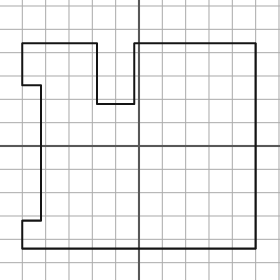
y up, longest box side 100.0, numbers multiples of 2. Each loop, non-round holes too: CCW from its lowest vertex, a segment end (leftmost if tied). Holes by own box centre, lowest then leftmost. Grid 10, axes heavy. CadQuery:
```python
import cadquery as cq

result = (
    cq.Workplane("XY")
    .moveTo(-50.0, -44.0)
    .lineTo(50.0, -44.0)
    .lineTo(50.0, 44.0)
    .lineTo(-2.0, 44.0)
    .lineTo(-2.0, 18.0)
    .lineTo(-18.0, 18.0)
    .lineTo(-18.0, 44.0)
    .lineTo(-50.0, 44.0)
    .lineTo(-50.0, 26.0)
    .lineTo(-42.0, 26.0)
    .lineTo(-42.0, -32.0)
    .lineTo(-50.0, -32.0)
    .close()
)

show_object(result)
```